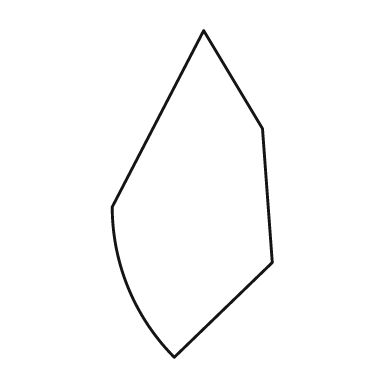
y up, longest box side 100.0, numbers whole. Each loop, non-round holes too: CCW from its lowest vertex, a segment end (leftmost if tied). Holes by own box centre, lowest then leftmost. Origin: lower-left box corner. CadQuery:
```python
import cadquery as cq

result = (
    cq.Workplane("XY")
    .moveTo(19.0, 0.0)
    .lineTo(49.0, 29.0)
    .lineTo(46.0, 70.0)
    .lineTo(28.0, 100.0)
    .lineTo(0.0, 46.0)
    .threePointArc((5.0, 21.0), (19.0, 0.0))
    .close()
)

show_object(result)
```